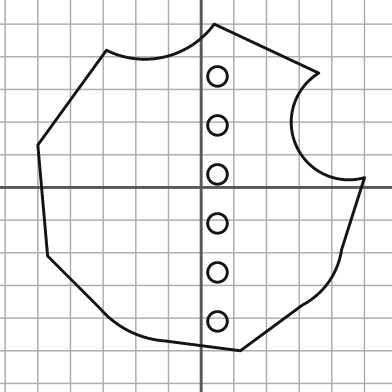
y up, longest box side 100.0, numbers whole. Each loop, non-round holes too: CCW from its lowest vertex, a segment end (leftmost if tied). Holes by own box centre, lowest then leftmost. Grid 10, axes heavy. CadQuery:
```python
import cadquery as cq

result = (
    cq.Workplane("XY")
    .moveTo(12.0, -50.0)
    .lineTo(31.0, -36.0)
    .threePointArc((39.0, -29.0), (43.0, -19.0))
    .lineTo(50.0, 3.0)
    .threePointArc((29.0, 13.0), (36.0, 35.0))
    .lineTo(4.0, 50.0)
    .threePointArc((-11.0, 40.0), (-29.0, 42.0))
    .lineTo(-50.0, 13.0)
    .lineTo(-47.0, -21.0)
    .lineTo(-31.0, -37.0)
    .threePointArc((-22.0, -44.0), (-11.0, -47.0))
    .close()
    .moveTo(5.0, -41.0)
    .circle(3.0)
    .moveTo(5.0, -26.0)
    .circle(3.0)
    .moveTo(5.0, -11.0)
    .circle(3.0)
    .moveTo(5.0, 4.0)
    .circle(3.0)
    .moveTo(5.0, 19.0)
    .circle(3.0)
    .moveTo(5.0, 34.0)
    .circle(3.0)
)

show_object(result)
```